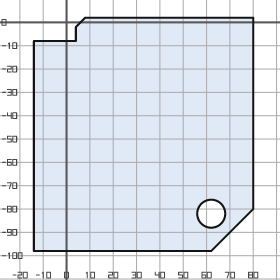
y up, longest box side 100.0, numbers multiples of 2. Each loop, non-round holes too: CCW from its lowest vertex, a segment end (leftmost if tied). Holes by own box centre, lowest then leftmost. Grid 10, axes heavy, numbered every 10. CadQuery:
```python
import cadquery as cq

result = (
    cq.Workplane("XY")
    .moveTo(-14.0, -98.0)
    .lineTo(62.0, -98.0)
    .lineTo(80.0, -80.0)
    .lineTo(80.0, 2.0)
    .lineTo(8.0, 2.0)
    .lineTo(4.0, -2.0)
    .lineTo(4.0, -8.0)
    .lineTo(-14.0, -8.0)
    .close()
    .moveTo(62.0, -82.0)
    .circle(6.0)
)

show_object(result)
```